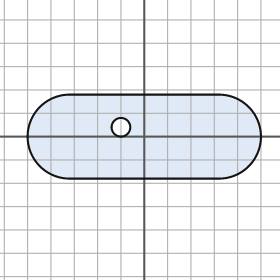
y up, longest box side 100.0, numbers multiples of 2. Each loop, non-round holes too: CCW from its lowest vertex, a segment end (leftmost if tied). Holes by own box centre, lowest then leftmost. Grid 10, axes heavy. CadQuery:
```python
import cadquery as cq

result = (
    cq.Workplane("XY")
    .moveTo(-32.0, -18.0)
    .lineTo(32.0, -18.0)
    .threePointArc((50.0, 0.0), (32.0, 18.0))
    .lineTo(-32.0, 18.0)
    .threePointArc((-50.0, 0.0), (-32.0, -18.0))
    .close()
    .moveTo(-10.0, 4.0)
    .circle(4.0)
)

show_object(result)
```